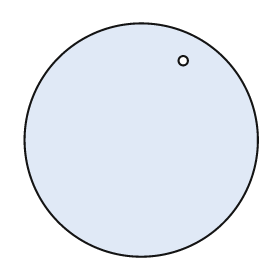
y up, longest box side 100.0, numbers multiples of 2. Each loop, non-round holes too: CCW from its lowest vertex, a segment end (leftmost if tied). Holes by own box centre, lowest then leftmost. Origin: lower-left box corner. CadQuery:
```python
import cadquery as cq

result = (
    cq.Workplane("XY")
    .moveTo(50.0, 50.0)
    .circle(50.0)
    .moveTo(68.0, 84.0)
    .circle(2.0)
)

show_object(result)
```